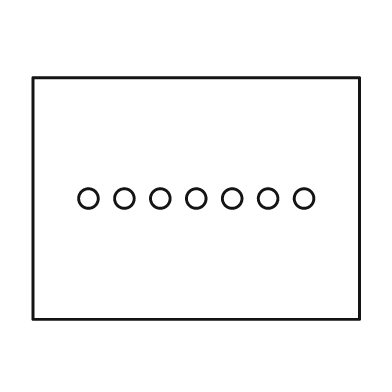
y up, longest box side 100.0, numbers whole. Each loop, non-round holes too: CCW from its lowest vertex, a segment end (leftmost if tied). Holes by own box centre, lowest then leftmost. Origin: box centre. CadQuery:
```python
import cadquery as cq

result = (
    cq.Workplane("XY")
    .moveTo(-50.0, -37.0)
    .lineTo(50.0, -37.0)
    .lineTo(50.0, 37.0)
    .lineTo(-50.0, 37.0)
    .close()
    .moveTo(-33.0, 0.0)
    .circle(3.0)
    .moveTo(-22.0, 0.0)
    .circle(3.0)
    .moveTo(-11.0, 0.0)
    .circle(3.0)
    .moveTo(0.0, 0.0)
    .circle(3.0)
    .moveTo(11.0, 0.0)
    .circle(3.0)
    .moveTo(22.0, 0.0)
    .circle(3.0)
    .moveTo(33.0, 0.0)
    .circle(3.0)
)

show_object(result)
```